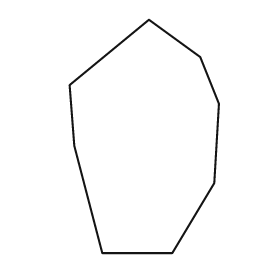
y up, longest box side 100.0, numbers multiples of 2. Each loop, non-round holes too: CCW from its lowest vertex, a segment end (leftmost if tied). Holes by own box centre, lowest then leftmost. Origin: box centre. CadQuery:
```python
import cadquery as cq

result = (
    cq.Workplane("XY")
    .moveTo(-18.0, -50.0)
    .lineTo(12.0, -50.0)
    .lineTo(30.0, -20.0)
    .lineTo(32.0, 14.0)
    .lineTo(24.0, 34.0)
    .lineTo(2.0, 50.0)
    .lineTo(-32.0, 22.0)
    .lineTo(-30.0, -4.0)
    .close()
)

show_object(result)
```